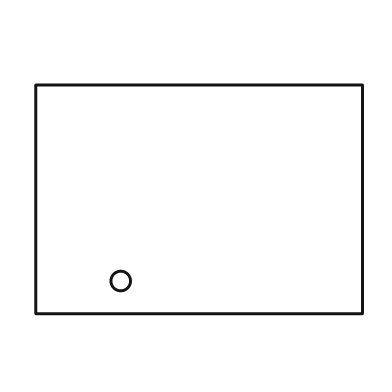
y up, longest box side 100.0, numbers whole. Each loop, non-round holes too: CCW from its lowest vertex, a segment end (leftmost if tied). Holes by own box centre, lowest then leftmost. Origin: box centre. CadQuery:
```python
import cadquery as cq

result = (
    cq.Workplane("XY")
    .moveTo(-50.0, -35.0)
    .lineTo(50.0, -35.0)
    .lineTo(50.0, 35.0)
    .lineTo(-50.0, 35.0)
    .close()
    .moveTo(-24.0, -25.0)
    .circle(3.0)
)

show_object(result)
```